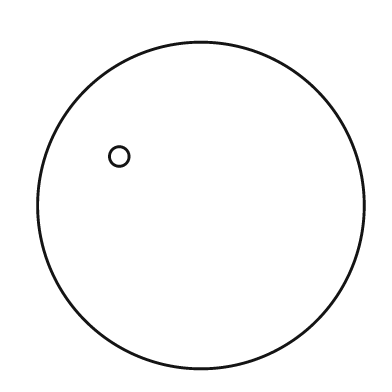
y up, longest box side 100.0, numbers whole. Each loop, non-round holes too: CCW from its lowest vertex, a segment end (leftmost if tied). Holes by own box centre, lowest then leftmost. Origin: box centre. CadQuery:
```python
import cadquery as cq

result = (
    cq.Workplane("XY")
    .moveTo(0.0, 0.0)
    .circle(50.0)
    .moveTo(-25.0, 15.0)
    .circle(3.0)
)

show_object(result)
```